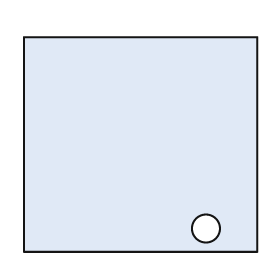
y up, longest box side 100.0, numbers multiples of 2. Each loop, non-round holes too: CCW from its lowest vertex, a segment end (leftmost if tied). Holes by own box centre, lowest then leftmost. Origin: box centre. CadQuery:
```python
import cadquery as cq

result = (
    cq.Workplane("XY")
    .moveTo(-50.0, -46.0)
    .lineTo(50.0, -46.0)
    .lineTo(50.0, 46.0)
    .lineTo(-50.0, 46.0)
    .close()
    .moveTo(28.0, -36.0)
    .circle(6.0)
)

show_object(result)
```